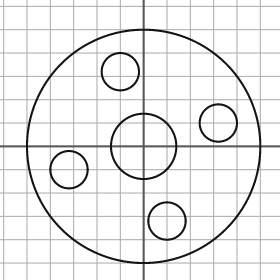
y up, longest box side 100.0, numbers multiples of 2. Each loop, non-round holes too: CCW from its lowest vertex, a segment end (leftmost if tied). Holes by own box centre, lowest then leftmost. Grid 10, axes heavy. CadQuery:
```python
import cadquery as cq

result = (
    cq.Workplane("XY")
    .moveTo(0.0, 0.0)
    .circle(50.0)
    .moveTo(10.0, -32.0)
    .circle(8.0)
    .moveTo(-32.0, -10.0)
    .circle(8.0)
    .moveTo(0.0, 0.0)
    .circle(14.0)
    .moveTo(32.0, 10.0)
    .circle(8.0)
    .moveTo(-10.0, 32.0)
    .circle(8.0)
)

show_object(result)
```